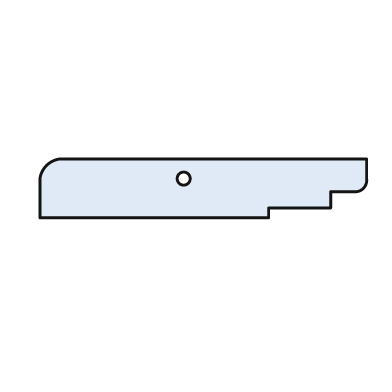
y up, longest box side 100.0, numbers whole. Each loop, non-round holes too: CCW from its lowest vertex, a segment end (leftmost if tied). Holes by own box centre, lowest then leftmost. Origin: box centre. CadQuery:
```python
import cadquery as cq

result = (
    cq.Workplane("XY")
    .moveTo(-50.0, -9.0)
    .lineTo(20.0, -9.0)
    .lineTo(20.0, -6.0)
    .lineTo(39.0, -6.0)
    .lineTo(39.0, -1.0)
    .lineTo(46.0, -1.0)
    .threePointArc((49.0, 0.0), (50.0, 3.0))
    .lineTo(50.0, 9.0)
    .lineTo(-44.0, 9.0)
    .threePointArc((-48.0, 7.0), (-50.0, 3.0))
    .close()
    .moveTo(-6.0, 3.0)
    .circle(2.0)
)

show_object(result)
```